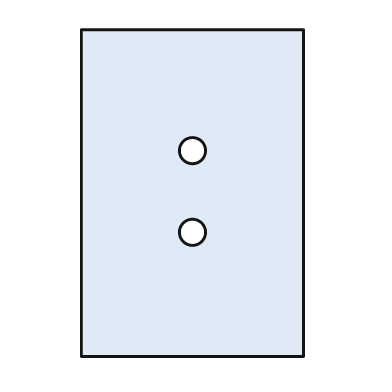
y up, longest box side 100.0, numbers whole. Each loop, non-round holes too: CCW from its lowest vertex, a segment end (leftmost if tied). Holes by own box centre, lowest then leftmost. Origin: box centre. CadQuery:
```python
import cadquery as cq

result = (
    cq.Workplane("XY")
    .moveTo(-34.0, -50.0)
    .lineTo(34.0, -50.0)
    .lineTo(34.0, 50.0)
    .lineTo(-34.0, 50.0)
    .close()
    .moveTo(0.0, -12.0)
    .circle(4.0)
    .moveTo(0.0, 13.0)
    .circle(4.0)
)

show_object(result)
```